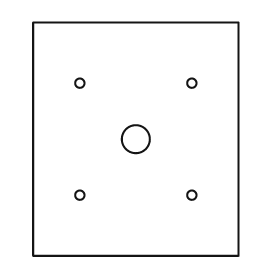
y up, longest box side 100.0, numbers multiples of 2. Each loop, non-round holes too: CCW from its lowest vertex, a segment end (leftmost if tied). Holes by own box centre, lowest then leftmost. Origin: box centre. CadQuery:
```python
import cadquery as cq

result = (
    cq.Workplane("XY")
    .moveTo(-44.0, -50.0)
    .lineTo(44.0, -50.0)
    .lineTo(44.0, 50.0)
    .lineTo(-44.0, 50.0)
    .close()
    .moveTo(-24.0, -24.0)
    .circle(2.0)
    .moveTo(24.0, -24.0)
    .circle(2.0)
    .moveTo(0.0, 0.0)
    .circle(6.0)
    .moveTo(-24.0, 24.0)
    .circle(2.0)
    .moveTo(24.0, 24.0)
    .circle(2.0)
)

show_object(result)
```